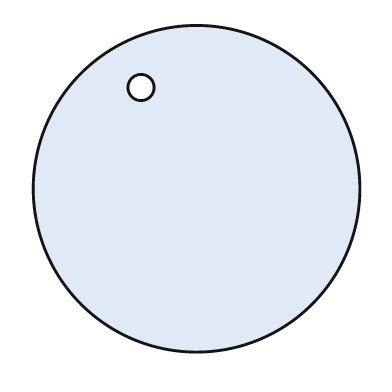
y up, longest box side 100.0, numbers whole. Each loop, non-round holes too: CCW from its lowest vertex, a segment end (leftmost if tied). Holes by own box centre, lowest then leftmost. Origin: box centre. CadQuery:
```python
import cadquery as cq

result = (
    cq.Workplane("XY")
    .moveTo(0.0, 0.0)
    .circle(50.0)
    .moveTo(-17.0, 31.0)
    .circle(4.0)
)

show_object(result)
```